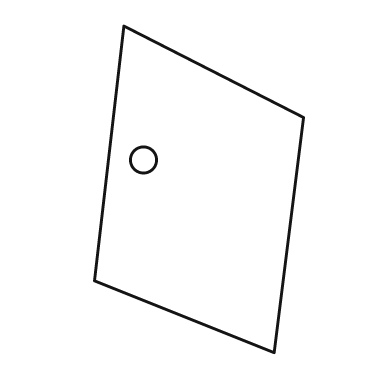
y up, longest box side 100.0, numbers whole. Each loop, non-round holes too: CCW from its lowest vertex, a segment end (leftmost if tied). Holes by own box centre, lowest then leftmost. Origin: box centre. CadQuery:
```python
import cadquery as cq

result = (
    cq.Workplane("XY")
    .moveTo(23.0, -50.0)
    .lineTo(32.0, 22.0)
    .lineTo(-23.0, 50.0)
    .lineTo(-32.0, -28.0)
    .close()
    .moveTo(-17.0, 9.0)
    .circle(4.0)
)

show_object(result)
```